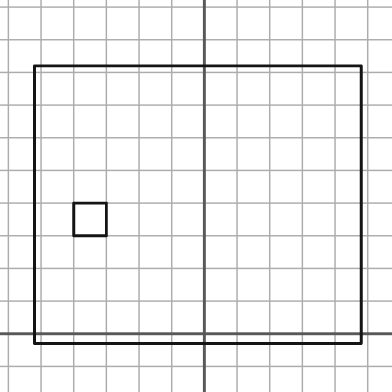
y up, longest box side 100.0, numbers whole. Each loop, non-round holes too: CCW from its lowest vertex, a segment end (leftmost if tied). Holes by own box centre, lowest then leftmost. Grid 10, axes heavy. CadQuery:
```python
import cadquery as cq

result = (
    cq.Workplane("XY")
    .moveTo(-52.0, -3.0)
    .lineTo(48.0, -3.0)
    .lineTo(48.0, 82.0)
    .lineTo(-52.0, 82.0)
    .close()
    .moveTo(-40.0, 30.0)
    .lineTo(-30.0, 30.0)
    .lineTo(-30.0, 40.0)
    .lineTo(-40.0, 40.0)
    .close()
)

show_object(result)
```